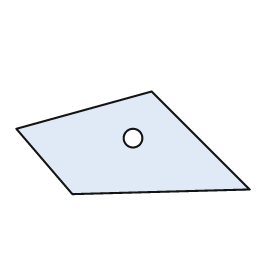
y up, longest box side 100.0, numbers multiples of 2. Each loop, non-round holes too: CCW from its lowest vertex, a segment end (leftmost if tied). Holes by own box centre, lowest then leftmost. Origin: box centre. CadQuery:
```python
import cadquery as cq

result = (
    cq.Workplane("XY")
    .moveTo(-26.0, -22.0)
    .lineTo(50.0, -20.0)
    .lineTo(8.0, 22.0)
    .lineTo(-50.0, 6.0)
    .close()
    .moveTo(0.0, 2.0)
    .circle(4.0)
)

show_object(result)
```